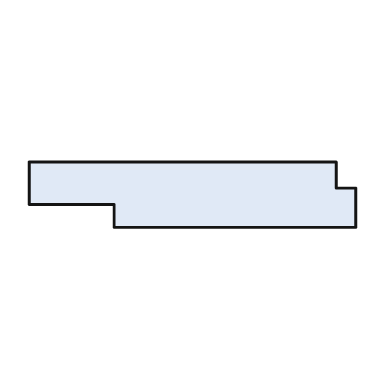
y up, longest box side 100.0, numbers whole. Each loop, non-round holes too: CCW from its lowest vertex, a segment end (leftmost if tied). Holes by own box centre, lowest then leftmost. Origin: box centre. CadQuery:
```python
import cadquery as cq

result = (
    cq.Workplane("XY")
    .moveTo(-24.0, -10.0)
    .lineTo(50.0, -10.0)
    .lineTo(50.0, 2.0)
    .lineTo(44.0, 2.0)
    .lineTo(44.0, 10.0)
    .lineTo(-50.0, 10.0)
    .lineTo(-50.0, -3.0)
    .lineTo(-24.0, -3.0)
    .close()
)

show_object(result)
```